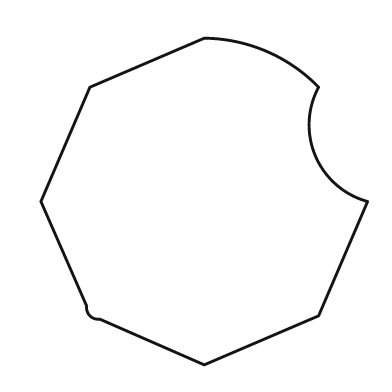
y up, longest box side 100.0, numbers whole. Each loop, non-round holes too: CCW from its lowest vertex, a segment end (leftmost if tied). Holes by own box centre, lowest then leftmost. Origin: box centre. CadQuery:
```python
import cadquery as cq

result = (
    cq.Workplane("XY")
    .moveTo(0.0, -50.0)
    .lineTo(35.0, -35.0)
    .lineTo(50.0, 0.0)
    .threePointArc((34.0, 14.0), (35.0, 35.0))
    .threePointArc((19.0, 46.0), (0.0, 50.0))
    .lineTo(-35.0, 35.0)
    .lineTo(-50.0, 0.0)
    .lineTo(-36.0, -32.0)
    .threePointArc((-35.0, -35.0), (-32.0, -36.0))
    .close()
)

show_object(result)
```